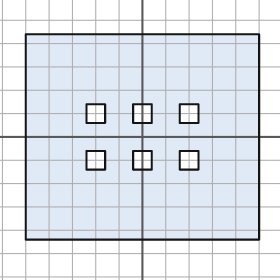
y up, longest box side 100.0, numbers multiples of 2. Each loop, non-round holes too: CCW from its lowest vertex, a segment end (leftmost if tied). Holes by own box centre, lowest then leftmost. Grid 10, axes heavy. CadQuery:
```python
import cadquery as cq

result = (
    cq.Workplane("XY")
    .moveTo(-50.0, -44.0)
    .lineTo(50.0, -44.0)
    .lineTo(50.0, 44.0)
    .lineTo(-50.0, 44.0)
    .close()
    .moveTo(-24.0, -14.0)
    .lineTo(-16.0, -14.0)
    .lineTo(-16.0, -6.0)
    .lineTo(-24.0, -6.0)
    .close()
    .moveTo(-4.0, -14.0)
    .lineTo(4.0, -14.0)
    .lineTo(4.0, -6.0)
    .lineTo(-4.0, -6.0)
    .close()
    .moveTo(16.0, -14.0)
    .lineTo(24.0, -14.0)
    .lineTo(24.0, -6.0)
    .lineTo(16.0, -6.0)
    .close()
    .moveTo(-24.0, 6.0)
    .lineTo(-16.0, 6.0)
    .lineTo(-16.0, 14.0)
    .lineTo(-24.0, 14.0)
    .close()
    .moveTo(-4.0, 6.0)
    .lineTo(4.0, 6.0)
    .lineTo(4.0, 14.0)
    .lineTo(-4.0, 14.0)
    .close()
    .moveTo(16.0, 6.0)
    .lineTo(24.0, 6.0)
    .lineTo(24.0, 14.0)
    .lineTo(16.0, 14.0)
    .close()
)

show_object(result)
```